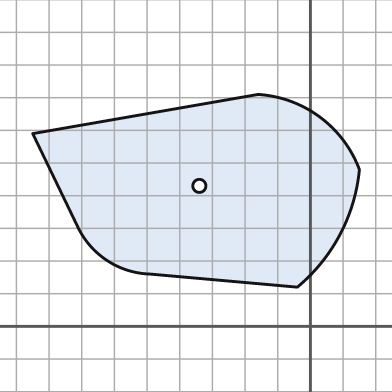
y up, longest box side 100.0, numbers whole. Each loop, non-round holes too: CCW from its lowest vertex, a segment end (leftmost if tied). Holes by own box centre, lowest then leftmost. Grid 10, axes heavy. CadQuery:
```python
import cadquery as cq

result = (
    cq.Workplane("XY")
    .moveTo(-4.0, 12.0)
    .threePointArc((9.0, 28.0), (15.0, 48.0))
    .threePointArc((3.0, 64.0), (-16.0, 71.0))
    .lineTo(-85.0, 59.0)
    .lineTo(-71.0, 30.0)
    .threePointArc((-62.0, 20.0), (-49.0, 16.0))
    .close()
    .moveTo(-34.0, 43.0)
    .circle(2.0)
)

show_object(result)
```